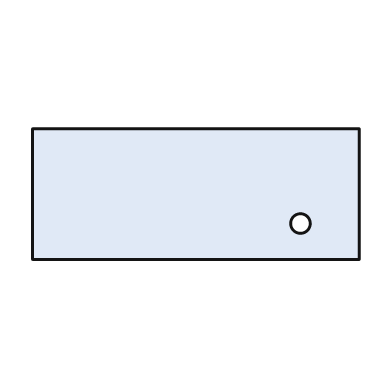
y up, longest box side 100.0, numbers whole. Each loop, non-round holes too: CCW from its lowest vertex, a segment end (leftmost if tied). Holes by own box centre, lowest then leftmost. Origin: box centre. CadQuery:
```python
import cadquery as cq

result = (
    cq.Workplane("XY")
    .moveTo(-50.0, -20.0)
    .lineTo(50.0, -20.0)
    .lineTo(50.0, 20.0)
    .lineTo(-50.0, 20.0)
    .close()
    .moveTo(32.0, -9.0)
    .circle(3.0)
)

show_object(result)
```